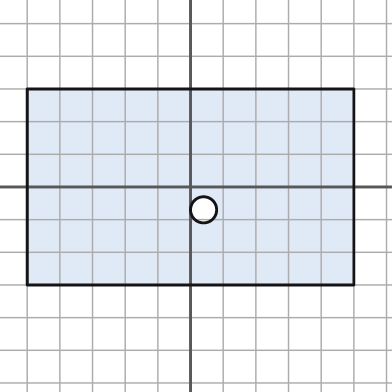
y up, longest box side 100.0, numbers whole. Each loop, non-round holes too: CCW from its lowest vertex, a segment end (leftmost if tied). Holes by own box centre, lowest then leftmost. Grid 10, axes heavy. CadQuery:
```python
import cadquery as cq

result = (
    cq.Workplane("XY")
    .moveTo(-50.0, -30.0)
    .lineTo(50.0, -30.0)
    .lineTo(50.0, 30.0)
    .lineTo(-50.0, 30.0)
    .close()
    .moveTo(4.0, -7.0)
    .circle(4.0)
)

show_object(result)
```